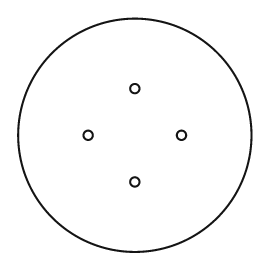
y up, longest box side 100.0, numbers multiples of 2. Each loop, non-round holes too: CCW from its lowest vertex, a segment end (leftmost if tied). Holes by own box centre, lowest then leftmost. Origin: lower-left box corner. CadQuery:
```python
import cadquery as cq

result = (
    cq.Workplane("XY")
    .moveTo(50.0, 50.0)
    .circle(50.0)
    .moveTo(50.0, 30.0)
    .circle(2.0)
    .moveTo(30.0, 50.0)
    .circle(2.0)
    .moveTo(70.0, 50.0)
    .circle(2.0)
    .moveTo(50.0, 70.0)
    .circle(2.0)
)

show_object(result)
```